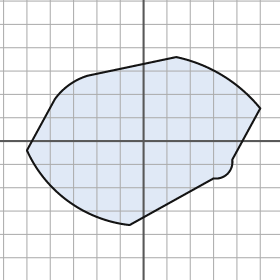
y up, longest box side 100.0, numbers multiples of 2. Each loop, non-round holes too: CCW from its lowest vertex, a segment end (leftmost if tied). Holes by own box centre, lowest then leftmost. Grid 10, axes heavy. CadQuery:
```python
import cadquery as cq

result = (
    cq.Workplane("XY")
    .moveTo(-6.0, -36.0)
    .lineTo(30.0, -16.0)
    .threePointArc((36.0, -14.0), (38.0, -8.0))
    .lineTo(50.0, 14.0)
    .threePointArc((34.0, 28.0), (14.0, 36.0))
    .lineTo(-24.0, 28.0)
    .threePointArc((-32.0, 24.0), (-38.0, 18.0))
    .lineTo(-50.0, -4.0)
    .threePointArc((-32.0, -26.0), (-6.0, -36.0))
    .close()
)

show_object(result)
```